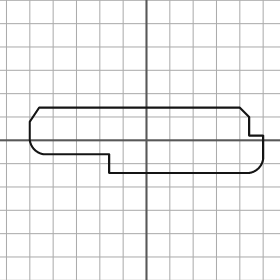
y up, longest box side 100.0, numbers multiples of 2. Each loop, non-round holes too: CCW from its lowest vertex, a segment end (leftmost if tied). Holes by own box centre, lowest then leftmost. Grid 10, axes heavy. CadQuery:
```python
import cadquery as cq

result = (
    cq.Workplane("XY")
    .moveTo(-16.0, -14.0)
    .lineTo(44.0, -14.0)
    .threePointArc((48.0, -12.0), (50.0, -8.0))
    .lineTo(50.0, 2.0)
    .lineTo(44.0, 2.0)
    .lineTo(44.0, 10.0)
    .lineTo(40.0, 14.0)
    .lineTo(-46.0, 14.0)
    .lineTo(-50.0, 8.0)
    .lineTo(-50.0, 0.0)
    .threePointArc((-48.0, -4.0), (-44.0, -6.0))
    .lineTo(-16.0, -6.0)
    .close()
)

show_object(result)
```